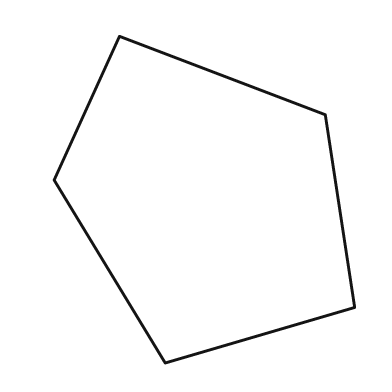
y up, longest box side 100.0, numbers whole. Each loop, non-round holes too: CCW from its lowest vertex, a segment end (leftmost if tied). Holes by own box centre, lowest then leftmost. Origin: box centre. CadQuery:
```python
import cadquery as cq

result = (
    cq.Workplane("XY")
    .moveTo(-12.0, -50.0)
    .lineTo(46.0, -33.0)
    .lineTo(37.0, 26.0)
    .lineTo(-26.0, 50.0)
    .lineTo(-46.0, 6.0)
    .close()
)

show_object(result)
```